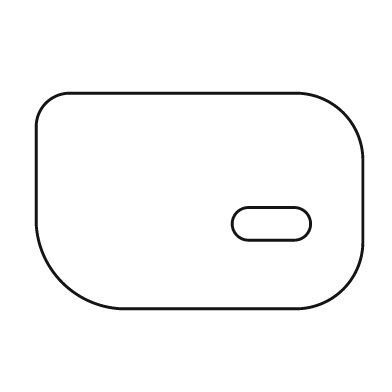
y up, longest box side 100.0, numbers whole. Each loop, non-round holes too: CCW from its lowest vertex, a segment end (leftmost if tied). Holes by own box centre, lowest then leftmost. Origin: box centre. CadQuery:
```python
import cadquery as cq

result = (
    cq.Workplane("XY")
    .moveTo(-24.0, -33.0)
    .lineTo(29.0, -33.0)
    .threePointArc((44.0, -27.0), (50.0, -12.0))
    .lineTo(50.0, 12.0)
    .threePointArc((44.0, 27.0), (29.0, 33.0))
    .lineTo(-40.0, 33.0)
    .threePointArc((-47.0, 30.0), (-50.0, 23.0))
    .lineTo(-50.0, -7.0)
    .threePointArc((-42.0, -25.0), (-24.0, -33.0))
    .close()
    .moveTo(15.0, -12.0)
    .lineTo(29.0, -12.0)
    .threePointArc((34.0, -7.0), (29.0, -2.0))
    .lineTo(15.0, -2.0)
    .threePointArc((10.0, -7.0), (15.0, -12.0))
    .close()
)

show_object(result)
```